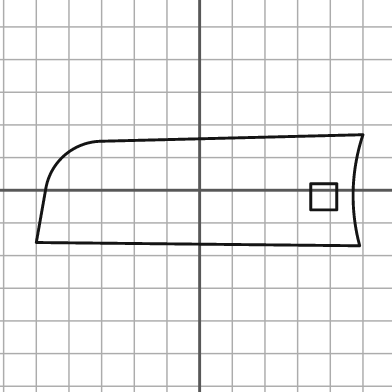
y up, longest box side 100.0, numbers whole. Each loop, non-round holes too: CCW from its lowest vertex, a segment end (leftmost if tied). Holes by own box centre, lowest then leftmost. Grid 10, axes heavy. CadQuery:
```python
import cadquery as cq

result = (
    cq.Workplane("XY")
    .moveTo(49.0, -17.0)
    .threePointArc((47.0, 0.0), (50.0, 17.0))
    .lineTo(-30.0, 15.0)
    .threePointArc((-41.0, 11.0), (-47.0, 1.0))
    .lineTo(-50.0, -16.0)
    .close()
    .moveTo(34.0, -6.0)
    .lineTo(42.0, -6.0)
    .lineTo(42.0, 2.0)
    .lineTo(34.0, 2.0)
    .close()
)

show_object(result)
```